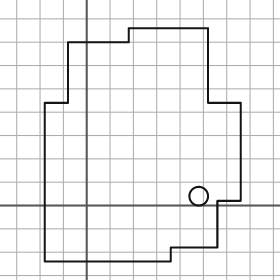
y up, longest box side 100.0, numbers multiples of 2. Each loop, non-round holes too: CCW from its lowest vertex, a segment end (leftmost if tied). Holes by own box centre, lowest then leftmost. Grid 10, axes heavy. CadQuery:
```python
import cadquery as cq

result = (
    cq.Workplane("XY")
    .moveTo(-18.0, -24.0)
    .lineTo(36.0, -24.0)
    .lineTo(36.0, -18.0)
    .lineTo(56.0, -18.0)
    .lineTo(56.0, 2.0)
    .lineTo(66.0, 2.0)
    .lineTo(66.0, 44.0)
    .lineTo(52.0, 44.0)
    .lineTo(52.0, 76.0)
    .lineTo(18.0, 76.0)
    .lineTo(18.0, 70.0)
    .lineTo(-8.0, 70.0)
    .lineTo(-8.0, 44.0)
    .lineTo(-18.0, 44.0)
    .close()
    .moveTo(48.0, 4.0)
    .circle(4.0)
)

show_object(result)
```